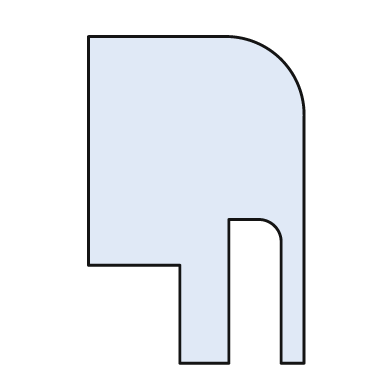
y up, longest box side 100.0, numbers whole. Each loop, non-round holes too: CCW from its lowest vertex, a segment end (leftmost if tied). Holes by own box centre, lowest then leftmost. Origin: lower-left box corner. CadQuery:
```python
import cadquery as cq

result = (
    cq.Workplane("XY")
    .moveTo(28.0, 0.0)
    .lineTo(43.0, 0.0)
    .lineTo(43.0, 44.0)
    .lineTo(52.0, 44.0)
    .threePointArc((57.0, 42.0), (59.0, 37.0))
    .lineTo(59.0, 0.0)
    .lineTo(66.0, 0.0)
    .lineTo(66.0, 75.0)
    .threePointArc((59.0, 93.0), (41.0, 100.0))
    .lineTo(0.0, 100.0)
    .lineTo(0.0, 30.0)
    .lineTo(28.0, 30.0)
    .close()
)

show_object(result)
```